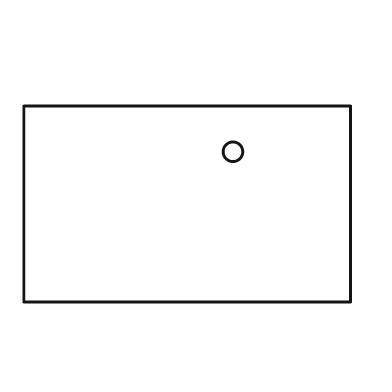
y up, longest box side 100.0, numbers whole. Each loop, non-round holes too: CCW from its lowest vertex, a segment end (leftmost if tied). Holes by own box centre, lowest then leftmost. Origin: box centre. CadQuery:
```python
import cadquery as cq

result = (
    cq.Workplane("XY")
    .moveTo(-50.0, -30.0)
    .lineTo(50.0, -30.0)
    .lineTo(50.0, 30.0)
    .lineTo(-50.0, 30.0)
    .close()
    .moveTo(14.0, 16.0)
    .circle(3.0)
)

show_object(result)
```